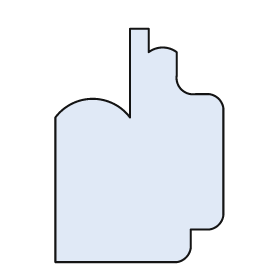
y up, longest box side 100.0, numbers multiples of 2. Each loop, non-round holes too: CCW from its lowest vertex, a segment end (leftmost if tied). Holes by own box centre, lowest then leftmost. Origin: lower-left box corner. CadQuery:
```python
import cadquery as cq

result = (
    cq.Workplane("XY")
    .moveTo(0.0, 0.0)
    .lineTo(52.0, 0.0)
    .threePointArc((56.0, 2.0), (58.0, 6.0))
    .lineTo(58.0, 14.0)
    .lineTo(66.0, 14.0)
    .threePointArc((70.0, 16.0), (72.0, 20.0))
    .lineTo(72.0, 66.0)
    .threePointArc((70.0, 70.0), (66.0, 72.0))
    .lineTo(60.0, 72.0)
    .threePointArc((54.0, 74.0), (52.0, 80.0))
    .lineTo(52.0, 90.0)
    .threePointArc((46.0, 92.0), (40.0, 90.0))
    .lineTo(40.0, 100.0)
    .lineTo(32.0, 100.0)
    .lineTo(32.0, 62.0)
    .threePointArc((16.0, 70.0), (0.0, 62.0))
    .close()
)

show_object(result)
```